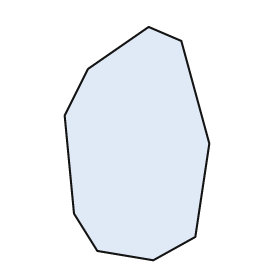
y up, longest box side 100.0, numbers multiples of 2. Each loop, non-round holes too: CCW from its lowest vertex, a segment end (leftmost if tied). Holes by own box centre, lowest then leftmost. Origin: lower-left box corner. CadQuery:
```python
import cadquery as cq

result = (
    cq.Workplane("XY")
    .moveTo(38.0, 0.0)
    .lineTo(56.0, 10.0)
    .lineTo(62.0, 50.0)
    .lineTo(50.0, 94.0)
    .lineTo(36.0, 100.0)
    .lineTo(10.0, 82.0)
    .lineTo(0.0, 62.0)
    .lineTo(4.0, 20.0)
    .lineTo(14.0, 4.0)
    .close()
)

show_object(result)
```